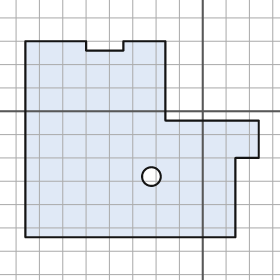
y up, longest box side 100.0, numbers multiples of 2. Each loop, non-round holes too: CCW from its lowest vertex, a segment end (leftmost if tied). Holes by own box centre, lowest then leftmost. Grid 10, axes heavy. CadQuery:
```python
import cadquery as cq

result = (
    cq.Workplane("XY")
    .moveTo(-76.0, -54.0)
    .lineTo(14.0, -54.0)
    .lineTo(14.0, -20.0)
    .lineTo(24.0, -20.0)
    .lineTo(24.0, -4.0)
    .lineTo(-16.0, -4.0)
    .lineTo(-16.0, 30.0)
    .lineTo(-34.0, 30.0)
    .lineTo(-34.0, 26.0)
    .lineTo(-50.0, 26.0)
    .lineTo(-50.0, 30.0)
    .lineTo(-76.0, 30.0)
    .close()
    .moveTo(-22.0, -28.0)
    .circle(4.0)
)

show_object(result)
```